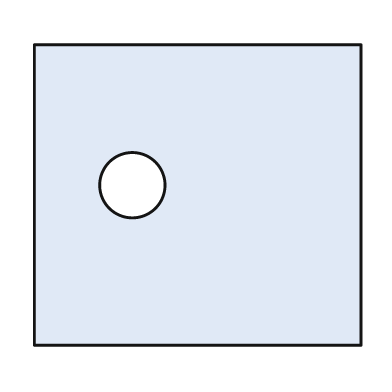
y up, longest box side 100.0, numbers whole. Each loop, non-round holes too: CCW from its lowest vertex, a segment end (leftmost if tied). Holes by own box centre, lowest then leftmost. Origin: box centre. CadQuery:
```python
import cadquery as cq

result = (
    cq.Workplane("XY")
    .moveTo(-50.0, -46.0)
    .lineTo(50.0, -46.0)
    .lineTo(50.0, 46.0)
    .lineTo(-50.0, 46.0)
    .close()
    .moveTo(-20.0, 3.0)
    .circle(10.0)
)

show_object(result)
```